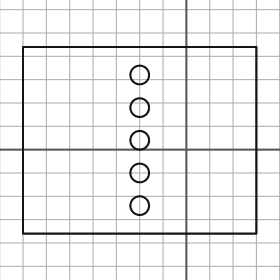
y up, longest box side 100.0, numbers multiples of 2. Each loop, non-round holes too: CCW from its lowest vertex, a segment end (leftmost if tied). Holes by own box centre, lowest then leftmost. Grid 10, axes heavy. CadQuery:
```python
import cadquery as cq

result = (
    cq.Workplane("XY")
    .moveTo(-70.0, -36.0)
    .lineTo(30.0, -36.0)
    .lineTo(30.0, 44.0)
    .lineTo(-70.0, 44.0)
    .close()
    .moveTo(-20.0, -24.0)
    .circle(4.0)
    .moveTo(-20.0, -10.0)
    .circle(4.0)
    .moveTo(-20.0, 4.0)
    .circle(4.0)
    .moveTo(-20.0, 18.0)
    .circle(4.0)
    .moveTo(-20.0, 32.0)
    .circle(4.0)
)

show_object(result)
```